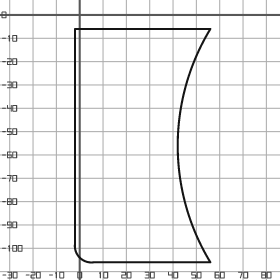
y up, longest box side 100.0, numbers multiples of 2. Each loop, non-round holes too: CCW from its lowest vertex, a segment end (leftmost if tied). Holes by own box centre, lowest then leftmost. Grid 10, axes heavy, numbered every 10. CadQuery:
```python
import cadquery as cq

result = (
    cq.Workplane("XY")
    .moveTo(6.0, -106.0)
    .lineTo(56.0, -106.0)
    .threePointArc((42.0, -56.0), (56.0, -6.0))
    .lineTo(-2.0, -6.0)
    .lineTo(-2.0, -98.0)
    .threePointArc((0.0, -104.0), (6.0, -106.0))
    .close()
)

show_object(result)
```